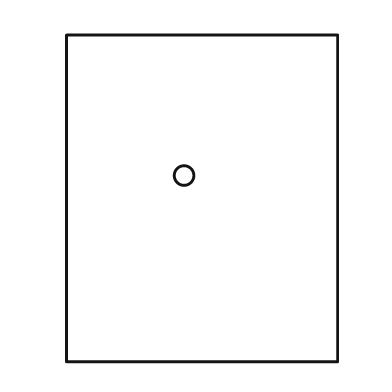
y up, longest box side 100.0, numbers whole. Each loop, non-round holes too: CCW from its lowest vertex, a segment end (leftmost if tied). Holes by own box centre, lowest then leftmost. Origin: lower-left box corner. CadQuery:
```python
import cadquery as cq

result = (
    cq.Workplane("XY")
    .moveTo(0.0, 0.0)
    .lineTo(83.0, 0.0)
    .lineTo(83.0, 100.0)
    .lineTo(0.0, 100.0)
    .close()
    .moveTo(36.0, 57.0)
    .circle(3.0)
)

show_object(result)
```